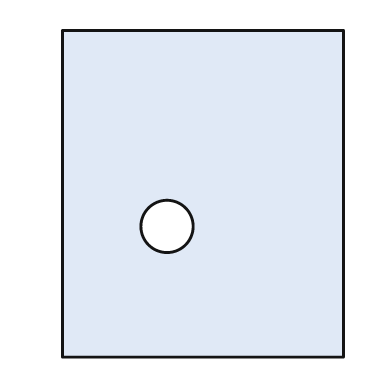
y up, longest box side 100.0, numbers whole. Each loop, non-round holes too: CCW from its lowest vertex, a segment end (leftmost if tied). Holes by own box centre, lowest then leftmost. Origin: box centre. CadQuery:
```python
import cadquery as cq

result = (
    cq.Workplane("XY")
    .moveTo(-43.0, -50.0)
    .lineTo(43.0, -50.0)
    .lineTo(43.0, 50.0)
    .lineTo(-43.0, 50.0)
    .close()
    .moveTo(-11.0, -10.0)
    .circle(8.0)
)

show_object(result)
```